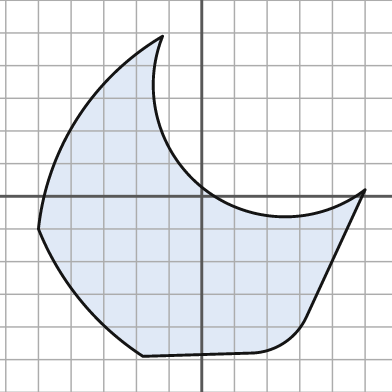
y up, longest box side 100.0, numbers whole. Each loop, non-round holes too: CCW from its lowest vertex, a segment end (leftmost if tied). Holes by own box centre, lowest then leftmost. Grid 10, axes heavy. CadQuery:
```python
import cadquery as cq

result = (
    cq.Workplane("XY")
    .moveTo(-18.0, -49.0)
    .lineTo(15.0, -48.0)
    .threePointArc((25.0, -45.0), (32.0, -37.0))
    .lineTo(50.0, 2.0)
    .threePointArc((1.0, 2.0), (-12.0, 49.0))
    .threePointArc((-38.0, 24.0), (-50.0, -10.0))
    .threePointArc((-37.0, -32.0), (-18.0, -49.0))
    .close()
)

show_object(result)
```